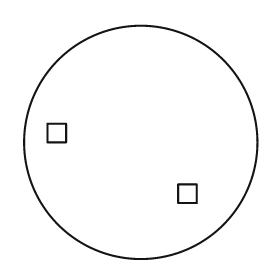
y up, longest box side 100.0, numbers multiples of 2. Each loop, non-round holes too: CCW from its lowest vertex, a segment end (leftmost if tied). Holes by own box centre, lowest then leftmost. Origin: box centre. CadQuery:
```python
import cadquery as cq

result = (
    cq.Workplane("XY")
    .moveTo(0.0, 0.0)
    .circle(50.0)
    .moveTo(16.0, -26.0)
    .lineTo(24.0, -26.0)
    .lineTo(24.0, -18.0)
    .lineTo(16.0, -18.0)
    .close()
    .moveTo(-40.0, 0.0)
    .lineTo(-32.0, 0.0)
    .lineTo(-32.0, 8.0)
    .lineTo(-40.0, 8.0)
    .close()
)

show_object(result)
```